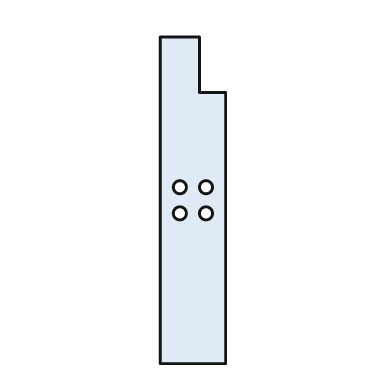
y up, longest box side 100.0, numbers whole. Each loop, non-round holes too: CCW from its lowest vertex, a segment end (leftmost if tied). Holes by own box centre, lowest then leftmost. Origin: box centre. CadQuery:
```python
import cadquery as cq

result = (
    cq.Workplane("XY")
    .moveTo(-10.0, -50.0)
    .lineTo(10.0, -50.0)
    .lineTo(10.0, 33.0)
    .lineTo(2.0, 33.0)
    .lineTo(2.0, 50.0)
    .lineTo(-10.0, 50.0)
    .close()
    .moveTo(-4.0, -4.0)
    .circle(2.0)
    .moveTo(4.0, -4.0)
    .circle(2.0)
    .moveTo(-4.0, 4.0)
    .circle(2.0)
    .moveTo(4.0, 4.0)
    .circle(2.0)
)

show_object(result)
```